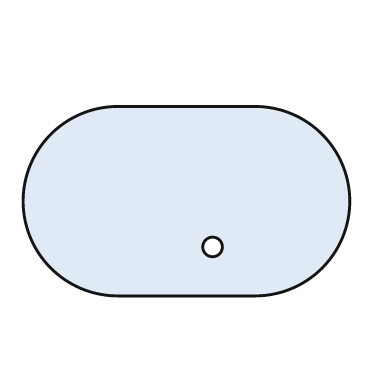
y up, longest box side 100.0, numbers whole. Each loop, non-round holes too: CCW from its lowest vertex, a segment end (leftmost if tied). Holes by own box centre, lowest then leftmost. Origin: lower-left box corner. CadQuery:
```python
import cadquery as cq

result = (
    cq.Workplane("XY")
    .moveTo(29.0, 0.0)
    .lineTo(71.0, 0.0)
    .threePointArc((100.0, 29.0), (71.0, 58.0))
    .lineTo(29.0, 58.0)
    .threePointArc((0.0, 29.0), (29.0, 0.0))
    .close()
    .moveTo(58.0, 15.0)
    .circle(3.0)
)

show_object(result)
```